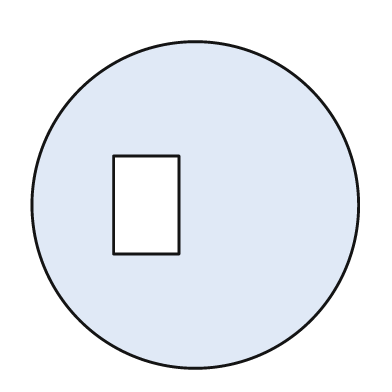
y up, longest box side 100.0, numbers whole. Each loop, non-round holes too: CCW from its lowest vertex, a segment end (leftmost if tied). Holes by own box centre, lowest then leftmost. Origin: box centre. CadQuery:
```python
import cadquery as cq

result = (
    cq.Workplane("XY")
    .moveTo(0.0, 0.0)
    .circle(50.0)
    .moveTo(-25.0, -15.0)
    .lineTo(-5.0, -15.0)
    .lineTo(-5.0, 15.0)
    .lineTo(-25.0, 15.0)
    .close()
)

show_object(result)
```